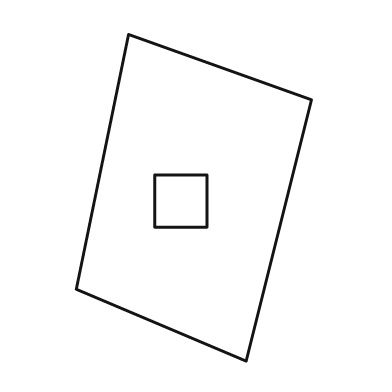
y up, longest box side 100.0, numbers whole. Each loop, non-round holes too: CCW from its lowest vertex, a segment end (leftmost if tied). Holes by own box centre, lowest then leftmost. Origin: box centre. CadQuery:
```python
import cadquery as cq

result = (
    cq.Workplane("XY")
    .moveTo(16.0, -50.0)
    .lineTo(36.0, 30.0)
    .lineTo(-20.0, 50.0)
    .lineTo(-36.0, -28.0)
    .close()
    .moveTo(-12.0, -9.0)
    .lineTo(4.0, -9.0)
    .lineTo(4.0, 7.0)
    .lineTo(-12.0, 7.0)
    .close()
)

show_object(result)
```